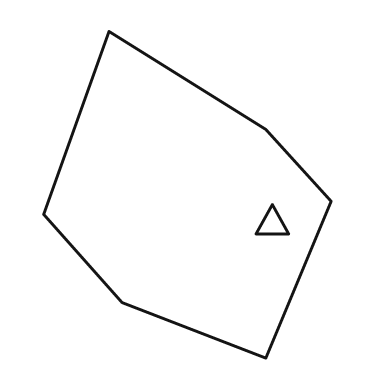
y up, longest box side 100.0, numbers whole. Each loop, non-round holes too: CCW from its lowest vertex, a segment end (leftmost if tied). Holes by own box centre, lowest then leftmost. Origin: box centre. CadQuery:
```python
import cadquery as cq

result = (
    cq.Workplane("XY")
    .moveTo(24.0, -50.0)
    .lineTo(44.0, -2.0)
    .lineTo(24.0, 20.0)
    .lineTo(-24.0, 50.0)
    .lineTo(-44.0, -6.0)
    .lineTo(-20.0, -33.0)
    .close()
    .moveTo(21.0, -12.0)
    .lineTo(31.0, -12.0)
    .lineTo(26.0, -3.0)
    .close()
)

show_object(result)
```